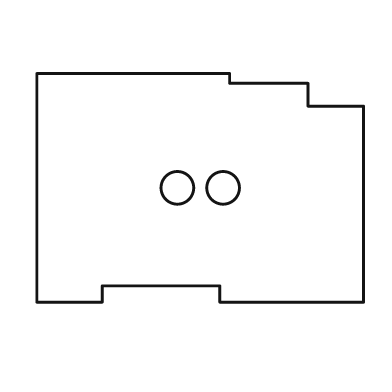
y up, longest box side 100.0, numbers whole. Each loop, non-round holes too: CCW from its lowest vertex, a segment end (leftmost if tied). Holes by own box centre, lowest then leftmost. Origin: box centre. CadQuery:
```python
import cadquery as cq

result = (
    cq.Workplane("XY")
    .moveTo(-50.0, -35.0)
    .lineTo(-30.0, -35.0)
    .lineTo(-30.0, -30.0)
    .lineTo(6.0, -30.0)
    .lineTo(6.0, -35.0)
    .lineTo(50.0, -35.0)
    .lineTo(50.0, 25.0)
    .lineTo(33.0, 25.0)
    .lineTo(33.0, 32.0)
    .lineTo(9.0, 32.0)
    .lineTo(9.0, 35.0)
    .lineTo(-50.0, 35.0)
    .close()
    .moveTo(-7.0, 0.0)
    .circle(5.0)
    .moveTo(7.0, 0.0)
    .circle(5.0)
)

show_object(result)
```